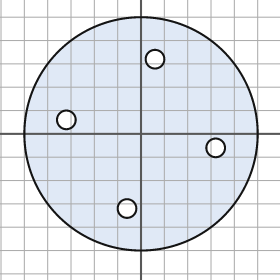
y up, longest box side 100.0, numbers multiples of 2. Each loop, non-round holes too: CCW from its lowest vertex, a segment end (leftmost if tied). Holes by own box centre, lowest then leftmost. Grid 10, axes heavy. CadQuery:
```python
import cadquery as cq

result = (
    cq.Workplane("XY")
    .moveTo(0.0, 0.0)
    .circle(50.0)
    .moveTo(-6.0, -32.0)
    .circle(4.0)
    .moveTo(32.0, -6.0)
    .circle(4.0)
    .moveTo(-32.0, 6.0)
    .circle(4.0)
    .moveTo(6.0, 32.0)
    .circle(4.0)
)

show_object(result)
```